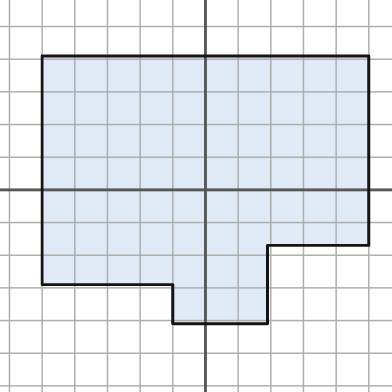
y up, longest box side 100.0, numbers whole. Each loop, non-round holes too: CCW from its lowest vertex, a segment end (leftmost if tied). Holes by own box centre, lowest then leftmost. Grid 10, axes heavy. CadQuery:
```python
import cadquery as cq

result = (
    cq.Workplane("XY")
    .moveTo(-10.0, -41.0)
    .lineTo(19.0, -41.0)
    .lineTo(19.0, -17.0)
    .lineTo(50.0, -17.0)
    .lineTo(50.0, 41.0)
    .lineTo(-50.0, 41.0)
    .lineTo(-50.0, -29.0)
    .lineTo(-10.0, -29.0)
    .close()
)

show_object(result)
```